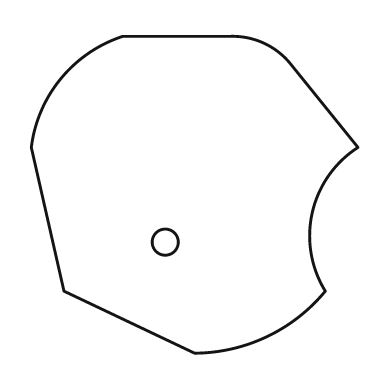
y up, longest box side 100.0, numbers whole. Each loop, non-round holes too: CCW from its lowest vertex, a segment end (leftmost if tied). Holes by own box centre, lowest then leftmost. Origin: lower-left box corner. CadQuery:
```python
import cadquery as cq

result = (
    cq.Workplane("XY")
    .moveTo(50.0, 0.0)
    .threePointArc((72.0, 5.0), (90.0, 19.0))
    .threePointArc((86.0, 43.0), (100.0, 63.0))
    .lineTo(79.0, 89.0)
    .threePointArc((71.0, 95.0), (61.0, 97.0))
    .lineTo(28.0, 97.0)
    .threePointArc((9.0, 84.0), (0.0, 63.0))
    .lineTo(10.0, 19.0)
    .close()
    .moveTo(41.0, 34.0)
    .circle(4.0)
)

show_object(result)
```